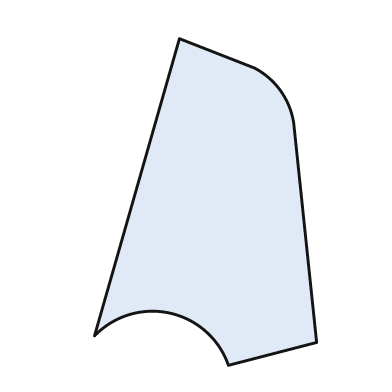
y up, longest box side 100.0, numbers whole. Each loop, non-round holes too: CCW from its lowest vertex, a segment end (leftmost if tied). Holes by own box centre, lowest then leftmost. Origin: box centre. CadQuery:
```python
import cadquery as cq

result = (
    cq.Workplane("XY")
    .moveTo(7.0, -50.0)
    .lineTo(34.0, -43.0)
    .lineTo(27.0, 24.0)
    .threePointArc((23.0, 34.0), (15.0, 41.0))
    .lineTo(-8.0, 50.0)
    .lineTo(-34.0, -41.0)
    .threePointArc((-11.0, -34.0), (7.0, -50.0))
    .close()
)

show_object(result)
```